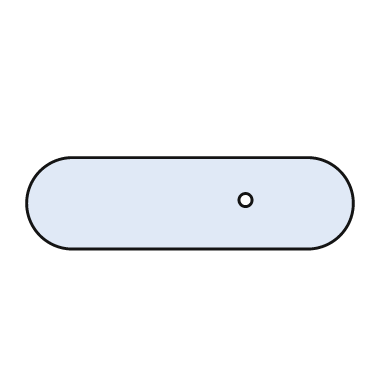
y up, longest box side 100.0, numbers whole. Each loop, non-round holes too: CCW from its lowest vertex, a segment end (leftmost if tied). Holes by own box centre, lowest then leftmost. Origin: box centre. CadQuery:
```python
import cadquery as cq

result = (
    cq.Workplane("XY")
    .moveTo(-36.0, -14.0)
    .lineTo(36.0, -14.0)
    .threePointArc((50.0, 0.0), (36.0, 14.0))
    .lineTo(-36.0, 14.0)
    .threePointArc((-50.0, 0.0), (-36.0, -14.0))
    .close()
    .moveTo(17.0, 1.0)
    .circle(2.0)
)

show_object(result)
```